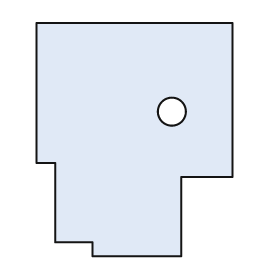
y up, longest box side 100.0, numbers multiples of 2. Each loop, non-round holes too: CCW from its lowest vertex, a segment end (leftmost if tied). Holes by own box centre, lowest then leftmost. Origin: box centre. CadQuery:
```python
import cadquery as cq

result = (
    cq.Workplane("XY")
    .moveTo(-18.0, -50.0)
    .lineTo(20.0, -50.0)
    .lineTo(20.0, -16.0)
    .lineTo(42.0, -16.0)
    .lineTo(42.0, 50.0)
    .lineTo(-42.0, 50.0)
    .lineTo(-42.0, -10.0)
    .lineTo(-34.0, -10.0)
    .lineTo(-34.0, -44.0)
    .lineTo(-18.0, -44.0)
    .close()
    .moveTo(16.0, 12.0)
    .circle(6.0)
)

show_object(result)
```